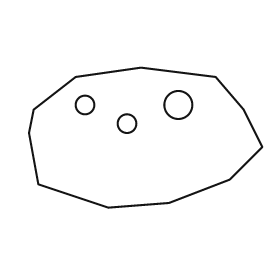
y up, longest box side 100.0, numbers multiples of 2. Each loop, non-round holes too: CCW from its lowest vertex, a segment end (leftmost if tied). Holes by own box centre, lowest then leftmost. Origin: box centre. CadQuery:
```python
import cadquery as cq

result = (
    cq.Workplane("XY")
    .moveTo(-16.0, -30.0)
    .lineTo(10.0, -28.0)
    .lineTo(36.0, -18.0)
    .lineTo(50.0, -4.0)
    .lineTo(42.0, 12.0)
    .lineTo(30.0, 26.0)
    .lineTo(-2.0, 30.0)
    .lineTo(-30.0, 26.0)
    .lineTo(-48.0, 12.0)
    .lineTo(-50.0, 2.0)
    .lineTo(-46.0, -20.0)
    .close()
    .moveTo(-8.0, 6.0)
    .circle(4.0)
    .moveTo(-26.0, 14.0)
    .circle(4.0)
    .moveTo(14.0, 14.0)
    .circle(6.0)
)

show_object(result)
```